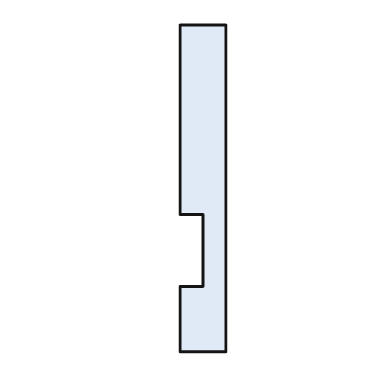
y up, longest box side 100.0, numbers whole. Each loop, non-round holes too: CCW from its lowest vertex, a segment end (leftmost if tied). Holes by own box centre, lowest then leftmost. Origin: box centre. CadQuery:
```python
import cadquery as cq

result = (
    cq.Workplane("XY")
    .moveTo(-7.0, -50.0)
    .lineTo(7.0, -50.0)
    .lineTo(7.0, 50.0)
    .lineTo(-7.0, 50.0)
    .lineTo(-7.0, -8.0)
    .lineTo(0.0, -8.0)
    .lineTo(0.0, -30.0)
    .lineTo(-7.0, -30.0)
    .close()
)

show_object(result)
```